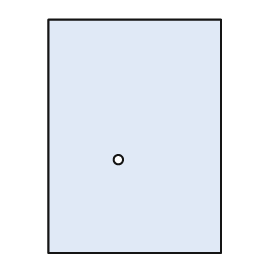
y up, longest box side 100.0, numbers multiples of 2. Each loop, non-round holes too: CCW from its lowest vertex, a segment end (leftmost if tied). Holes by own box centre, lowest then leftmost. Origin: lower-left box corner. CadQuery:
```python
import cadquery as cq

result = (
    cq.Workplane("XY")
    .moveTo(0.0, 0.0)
    .lineTo(74.0, 0.0)
    .lineTo(74.0, 100.0)
    .lineTo(0.0, 100.0)
    .close()
    .moveTo(30.0, 40.0)
    .circle(2.0)
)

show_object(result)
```